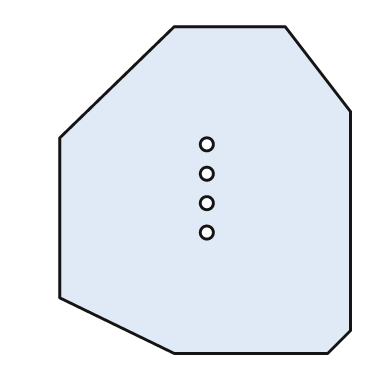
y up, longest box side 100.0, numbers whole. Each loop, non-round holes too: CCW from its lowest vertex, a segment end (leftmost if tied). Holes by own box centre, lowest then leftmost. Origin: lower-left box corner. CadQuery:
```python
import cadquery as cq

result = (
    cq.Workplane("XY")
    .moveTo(35.0, 0.0)
    .lineTo(82.0, 0.0)
    .lineTo(89.0, 7.0)
    .lineTo(89.0, 74.0)
    .lineTo(69.0, 100.0)
    .lineTo(35.0, 100.0)
    .lineTo(0.0, 66.0)
    .lineTo(0.0, 17.0)
    .close()
    .moveTo(45.0, 37.0)
    .circle(2.0)
    .moveTo(45.0, 46.0)
    .circle(2.0)
    .moveTo(45.0, 55.0)
    .circle(2.0)
    .moveTo(45.0, 64.0)
    .circle(2.0)
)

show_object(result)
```